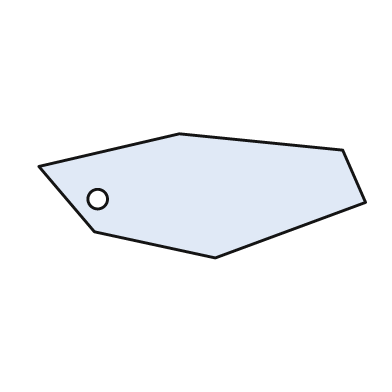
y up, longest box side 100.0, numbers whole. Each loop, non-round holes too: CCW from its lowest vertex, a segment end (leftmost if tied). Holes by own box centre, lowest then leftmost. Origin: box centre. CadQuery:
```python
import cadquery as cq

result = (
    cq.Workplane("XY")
    .moveTo(4.0, -19.0)
    .lineTo(50.0, -2.0)
    .lineTo(43.0, 14.0)
    .lineTo(-7.0, 19.0)
    .lineTo(-50.0, 9.0)
    .lineTo(-33.0, -11.0)
    .close()
    .moveTo(-32.0, -1.0)
    .circle(3.0)
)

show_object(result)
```